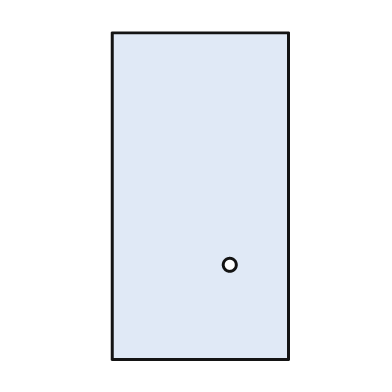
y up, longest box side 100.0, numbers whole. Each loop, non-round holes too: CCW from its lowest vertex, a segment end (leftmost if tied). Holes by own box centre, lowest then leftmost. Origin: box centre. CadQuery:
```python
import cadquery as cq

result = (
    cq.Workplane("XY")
    .moveTo(-27.0, -50.0)
    .lineTo(27.0, -50.0)
    .lineTo(27.0, 50.0)
    .lineTo(-27.0, 50.0)
    .close()
    .moveTo(9.0, -21.0)
    .circle(2.0)
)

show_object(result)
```